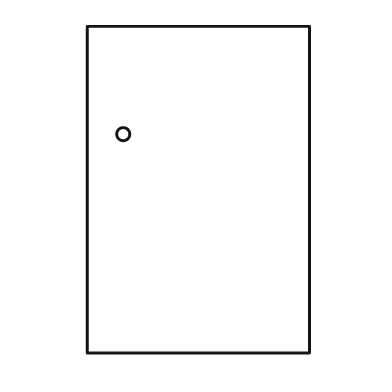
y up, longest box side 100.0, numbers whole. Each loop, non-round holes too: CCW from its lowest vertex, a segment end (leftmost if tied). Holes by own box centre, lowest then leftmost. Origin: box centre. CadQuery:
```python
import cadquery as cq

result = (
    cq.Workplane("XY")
    .moveTo(-34.0, -50.0)
    .lineTo(34.0, -50.0)
    .lineTo(34.0, 50.0)
    .lineTo(-34.0, 50.0)
    .close()
    .moveTo(-23.0, 17.0)
    .circle(2.0)
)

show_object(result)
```